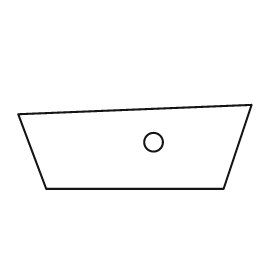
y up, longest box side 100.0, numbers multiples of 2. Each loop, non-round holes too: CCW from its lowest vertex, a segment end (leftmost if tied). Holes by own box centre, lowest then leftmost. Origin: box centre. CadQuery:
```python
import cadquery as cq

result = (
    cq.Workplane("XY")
    .moveTo(-38.0, -18.0)
    .lineTo(38.0, -18.0)
    .lineTo(50.0, 18.0)
    .lineTo(-50.0, 14.0)
    .close()
    .moveTo(8.0, 2.0)
    .circle(4.0)
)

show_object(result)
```